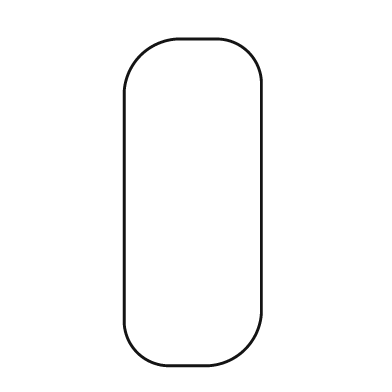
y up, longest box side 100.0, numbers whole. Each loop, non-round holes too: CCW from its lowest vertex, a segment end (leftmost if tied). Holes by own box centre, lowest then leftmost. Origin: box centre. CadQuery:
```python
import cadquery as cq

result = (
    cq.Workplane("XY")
    .moveTo(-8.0, -50.0)
    .lineTo(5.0, -50.0)
    .threePointArc((16.0, -45.0), (21.0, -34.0))
    .lineTo(21.0, 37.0)
    .threePointArc((17.0, 46.0), (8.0, 50.0))
    .lineTo(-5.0, 50.0)
    .threePointArc((-16.0, 45.0), (-21.0, 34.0))
    .lineTo(-21.0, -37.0)
    .threePointArc((-17.0, -46.0), (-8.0, -50.0))
    .close()
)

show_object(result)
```